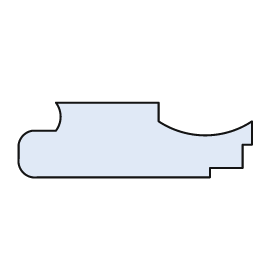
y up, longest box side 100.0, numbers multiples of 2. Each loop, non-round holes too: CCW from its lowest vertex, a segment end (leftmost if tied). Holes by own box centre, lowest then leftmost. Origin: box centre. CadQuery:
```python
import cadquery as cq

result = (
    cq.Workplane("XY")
    .moveTo(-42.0, -16.0)
    .lineTo(32.0, -16.0)
    .lineTo(32.0, -12.0)
    .lineTo(46.0, -12.0)
    .lineTo(46.0, -2.0)
    .lineTo(50.0, -2.0)
    .lineTo(50.0, 8.0)
    .threePointArc((30.0, 2.0), (10.0, 8.0))
    .lineTo(10.0, 16.0)
    .lineTo(-34.0, 16.0)
    .threePointArc((-32.0, 10.0), (-34.0, 4.0))
    .lineTo(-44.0, 4.0)
    .threePointArc((-48.0, 2.0), (-50.0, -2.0))
    .lineTo(-50.0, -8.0)
    .threePointArc((-48.0, -14.0), (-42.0, -16.0))
    .close()
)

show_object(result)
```